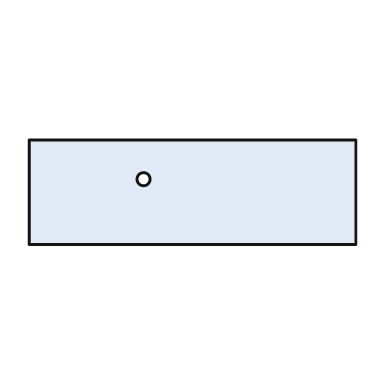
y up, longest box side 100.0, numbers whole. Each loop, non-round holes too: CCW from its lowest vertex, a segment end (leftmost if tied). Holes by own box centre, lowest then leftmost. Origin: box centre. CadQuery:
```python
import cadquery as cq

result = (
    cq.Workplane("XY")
    .moveTo(-50.0, -16.0)
    .lineTo(50.0, -16.0)
    .lineTo(50.0, 16.0)
    .lineTo(-50.0, 16.0)
    .close()
    .moveTo(-15.0, 4.0)
    .circle(2.0)
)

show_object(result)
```